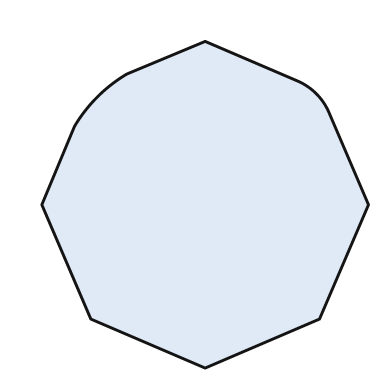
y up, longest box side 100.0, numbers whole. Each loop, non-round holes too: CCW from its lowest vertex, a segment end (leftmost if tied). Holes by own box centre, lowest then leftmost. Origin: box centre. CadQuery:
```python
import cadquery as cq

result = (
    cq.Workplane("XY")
    .moveTo(0.0, -50.0)
    .lineTo(35.0, -35.0)
    .lineTo(50.0, 0.0)
    .lineTo(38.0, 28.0)
    .threePointArc((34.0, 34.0), (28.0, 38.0))
    .lineTo(0.0, 50.0)
    .lineTo(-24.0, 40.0)
    .threePointArc((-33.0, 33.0), (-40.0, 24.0))
    .lineTo(-50.0, 0.0)
    .lineTo(-35.0, -35.0)
    .close()
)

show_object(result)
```